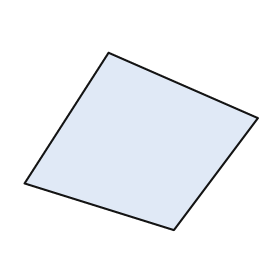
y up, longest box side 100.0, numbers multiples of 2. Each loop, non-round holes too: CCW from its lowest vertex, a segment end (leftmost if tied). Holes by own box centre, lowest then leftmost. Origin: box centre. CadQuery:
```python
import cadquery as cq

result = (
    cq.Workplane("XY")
    .moveTo(14.0, -38.0)
    .lineTo(50.0, 10.0)
    .lineTo(-14.0, 38.0)
    .lineTo(-50.0, -18.0)
    .close()
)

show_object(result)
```